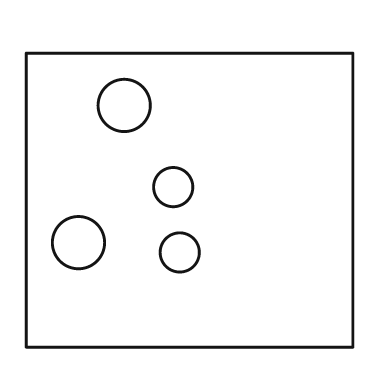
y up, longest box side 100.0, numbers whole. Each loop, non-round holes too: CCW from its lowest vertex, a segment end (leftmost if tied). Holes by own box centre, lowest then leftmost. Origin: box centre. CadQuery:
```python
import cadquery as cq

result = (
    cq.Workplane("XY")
    .moveTo(-50.0, -45.0)
    .lineTo(50.0, -45.0)
    .lineTo(50.0, 45.0)
    .lineTo(-50.0, 45.0)
    .close()
    .moveTo(-3.0, -16.0)
    .circle(6.0)
    .moveTo(-34.0, -13.0)
    .circle(8.0)
    .moveTo(-5.0, 4.0)
    .circle(6.0)
    .moveTo(-20.0, 29.0)
    .circle(8.0)
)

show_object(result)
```